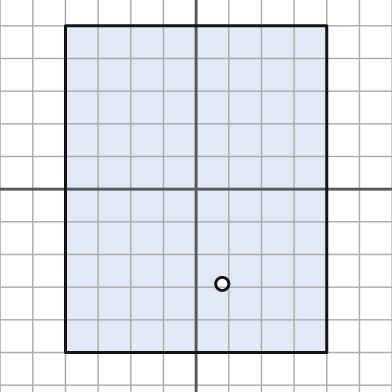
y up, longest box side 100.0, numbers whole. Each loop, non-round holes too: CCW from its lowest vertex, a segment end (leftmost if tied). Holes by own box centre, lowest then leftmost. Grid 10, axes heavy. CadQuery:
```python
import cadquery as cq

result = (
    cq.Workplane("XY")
    .moveTo(-40.0, -50.0)
    .lineTo(40.0, -50.0)
    .lineTo(40.0, 50.0)
    .lineTo(-40.0, 50.0)
    .close()
    .moveTo(8.0, -29.0)
    .circle(2.0)
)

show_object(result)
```